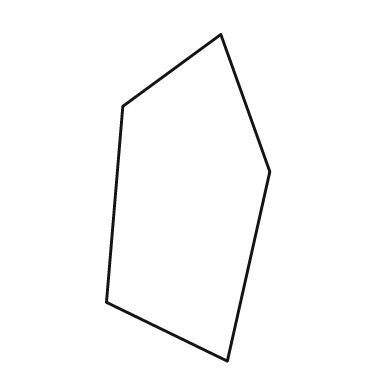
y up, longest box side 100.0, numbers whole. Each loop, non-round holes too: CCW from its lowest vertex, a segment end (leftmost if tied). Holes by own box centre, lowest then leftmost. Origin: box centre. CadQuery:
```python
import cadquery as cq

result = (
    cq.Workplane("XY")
    .moveTo(12.0, -50.0)
    .lineTo(25.0, 8.0)
    .lineTo(10.0, 50.0)
    .lineTo(-20.0, 28.0)
    .lineTo(-25.0, -32.0)
    .close()
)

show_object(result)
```